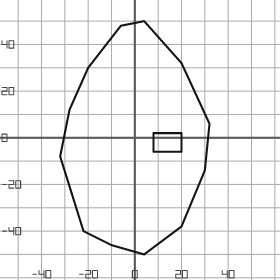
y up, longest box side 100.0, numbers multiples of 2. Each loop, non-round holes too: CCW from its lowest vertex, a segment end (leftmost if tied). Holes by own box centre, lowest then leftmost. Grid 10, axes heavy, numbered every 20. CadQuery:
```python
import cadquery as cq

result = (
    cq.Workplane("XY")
    .moveTo(4.0, -50.0)
    .lineTo(20.0, -38.0)
    .lineTo(30.0, -14.0)
    .lineTo(32.0, 6.0)
    .lineTo(20.0, 32.0)
    .lineTo(4.0, 50.0)
    .lineTo(-6.0, 48.0)
    .lineTo(-20.0, 30.0)
    .lineTo(-28.0, 12.0)
    .lineTo(-32.0, -8.0)
    .lineTo(-22.0, -40.0)
    .lineTo(-10.0, -46.0)
    .close()
    .moveTo(8.0, -6.0)
    .lineTo(20.0, -6.0)
    .lineTo(20.0, 2.0)
    .lineTo(8.0, 2.0)
    .close()
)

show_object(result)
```